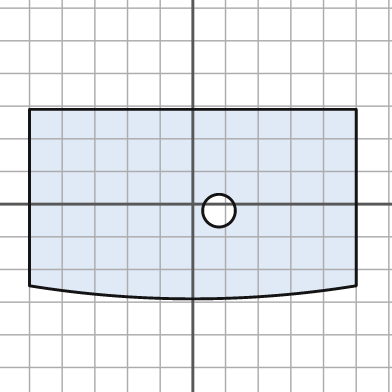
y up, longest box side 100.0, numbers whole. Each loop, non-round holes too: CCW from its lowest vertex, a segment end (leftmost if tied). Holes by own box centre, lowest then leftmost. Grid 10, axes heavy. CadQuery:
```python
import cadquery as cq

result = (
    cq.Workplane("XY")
    .moveTo(-50.0, -25.0)
    .threePointArc((0.0, -29.0), (50.0, -25.0))
    .lineTo(50.0, 29.0)
    .lineTo(-50.0, 29.0)
    .close()
    .moveTo(8.0, -2.0)
    .circle(5.0)
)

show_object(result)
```